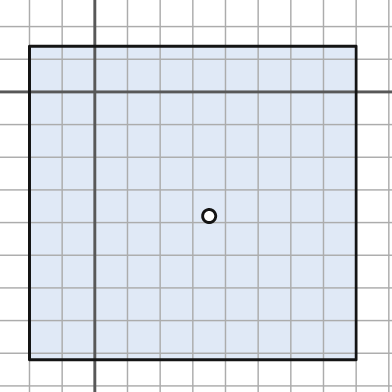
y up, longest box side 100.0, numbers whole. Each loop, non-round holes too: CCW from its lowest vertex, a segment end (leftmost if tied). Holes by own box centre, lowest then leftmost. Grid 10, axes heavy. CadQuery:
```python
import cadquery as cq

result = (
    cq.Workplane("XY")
    .moveTo(-20.0, -82.0)
    .lineTo(80.0, -82.0)
    .lineTo(80.0, 14.0)
    .lineTo(-20.0, 14.0)
    .close()
    .moveTo(35.0, -38.0)
    .circle(2.0)
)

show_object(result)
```